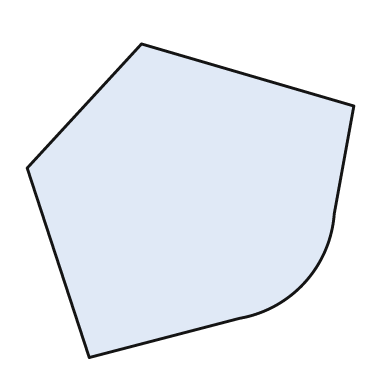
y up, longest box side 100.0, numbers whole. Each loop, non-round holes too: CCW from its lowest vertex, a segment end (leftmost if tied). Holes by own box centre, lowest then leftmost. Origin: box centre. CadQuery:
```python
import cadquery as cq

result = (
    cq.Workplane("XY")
    .moveTo(-31.0, -48.0)
    .lineTo(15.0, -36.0)
    .threePointArc((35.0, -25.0), (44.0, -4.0))
    .lineTo(50.0, 29.0)
    .lineTo(-15.0, 48.0)
    .lineTo(-50.0, 10.0)
    .close()
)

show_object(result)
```